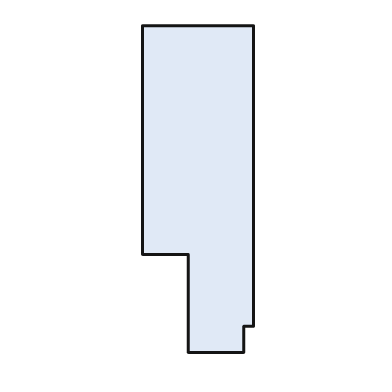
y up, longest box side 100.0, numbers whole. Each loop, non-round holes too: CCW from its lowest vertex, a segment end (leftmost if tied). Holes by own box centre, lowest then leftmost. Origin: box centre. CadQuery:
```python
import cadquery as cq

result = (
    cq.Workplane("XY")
    .moveTo(-3.0, -50.0)
    .lineTo(14.0, -50.0)
    .lineTo(14.0, -42.0)
    .lineTo(17.0, -42.0)
    .lineTo(17.0, 50.0)
    .lineTo(-17.0, 50.0)
    .lineTo(-17.0, -20.0)
    .lineTo(-3.0, -20.0)
    .close()
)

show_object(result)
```